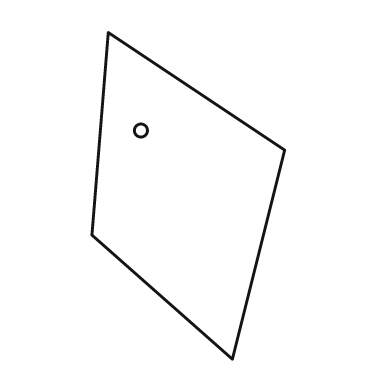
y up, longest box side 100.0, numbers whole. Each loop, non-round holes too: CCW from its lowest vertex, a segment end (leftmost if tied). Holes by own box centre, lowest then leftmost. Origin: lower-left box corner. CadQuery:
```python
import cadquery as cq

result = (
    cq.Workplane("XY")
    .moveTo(43.0, 0.0)
    .lineTo(59.0, 64.0)
    .lineTo(5.0, 100.0)
    .lineTo(0.0, 38.0)
    .close()
    .moveTo(15.0, 70.0)
    .circle(2.0)
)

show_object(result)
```